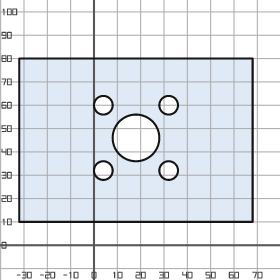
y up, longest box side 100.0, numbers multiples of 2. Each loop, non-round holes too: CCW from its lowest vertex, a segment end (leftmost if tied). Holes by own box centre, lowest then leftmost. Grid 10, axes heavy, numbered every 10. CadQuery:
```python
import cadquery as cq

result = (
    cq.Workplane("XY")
    .moveTo(-32.0, 10.0)
    .lineTo(68.0, 10.0)
    .lineTo(68.0, 80.0)
    .lineTo(-32.0, 80.0)
    .close()
    .moveTo(4.0, 32.0)
    .circle(4.0)
    .moveTo(32.0, 32.0)
    .circle(4.0)
    .moveTo(18.0, 46.0)
    .circle(10.0)
    .moveTo(4.0, 60.0)
    .circle(4.0)
    .moveTo(32.0, 60.0)
    .circle(4.0)
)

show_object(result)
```